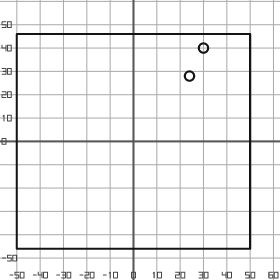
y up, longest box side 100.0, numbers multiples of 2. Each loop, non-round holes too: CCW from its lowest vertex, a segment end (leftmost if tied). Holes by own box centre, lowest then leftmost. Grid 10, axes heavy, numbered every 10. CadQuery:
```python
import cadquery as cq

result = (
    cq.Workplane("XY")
    .moveTo(-50.0, -46.0)
    .lineTo(50.0, -46.0)
    .lineTo(50.0, 46.0)
    .lineTo(-50.0, 46.0)
    .close()
    .moveTo(24.0, 28.0)
    .circle(2.0)
    .moveTo(30.0, 40.0)
    .circle(2.0)
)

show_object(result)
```